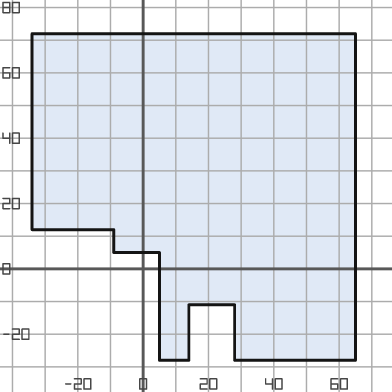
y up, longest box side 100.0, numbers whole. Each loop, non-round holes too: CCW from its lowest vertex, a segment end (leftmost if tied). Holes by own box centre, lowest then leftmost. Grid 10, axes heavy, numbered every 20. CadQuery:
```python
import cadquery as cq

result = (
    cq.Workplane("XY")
    .moveTo(5.0, -28.0)
    .lineTo(14.0, -28.0)
    .lineTo(14.0, -11.0)
    .lineTo(28.0, -11.0)
    .lineTo(28.0, -28.0)
    .lineTo(65.0, -28.0)
    .lineTo(65.0, 72.0)
    .lineTo(-34.0, 72.0)
    .lineTo(-34.0, 12.0)
    .lineTo(-9.0, 12.0)
    .lineTo(-9.0, 5.0)
    .lineTo(5.0, 5.0)
    .close()
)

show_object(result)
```